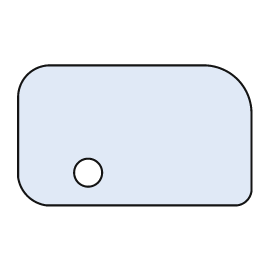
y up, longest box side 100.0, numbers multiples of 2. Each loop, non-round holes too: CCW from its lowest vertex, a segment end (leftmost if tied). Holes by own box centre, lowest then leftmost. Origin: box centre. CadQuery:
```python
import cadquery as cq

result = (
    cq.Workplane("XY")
    .moveTo(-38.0, -30.0)
    .lineTo(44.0, -30.0)
    .threePointArc((48.0, -28.0), (50.0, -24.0))
    .lineTo(50.0, 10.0)
    .threePointArc((44.0, 24.0), (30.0, 30.0))
    .lineTo(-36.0, 30.0)
    .threePointArc((-46.0, 26.0), (-50.0, 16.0))
    .lineTo(-50.0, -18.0)
    .threePointArc((-46.0, -26.0), (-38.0, -30.0))
    .close()
    .moveTo(-20.0, -16.0)
    .circle(6.0)
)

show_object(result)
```